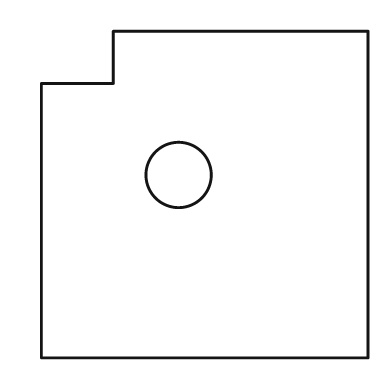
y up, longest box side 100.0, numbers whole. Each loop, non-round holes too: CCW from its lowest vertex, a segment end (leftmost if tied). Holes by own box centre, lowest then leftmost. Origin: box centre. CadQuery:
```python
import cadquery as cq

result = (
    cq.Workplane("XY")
    .moveTo(-50.0, -50.0)
    .lineTo(50.0, -50.0)
    .lineTo(50.0, 50.0)
    .lineTo(-28.0, 50.0)
    .lineTo(-28.0, 34.0)
    .lineTo(-50.0, 34.0)
    .close()
    .moveTo(-8.0, 6.0)
    .circle(10.0)
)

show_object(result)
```